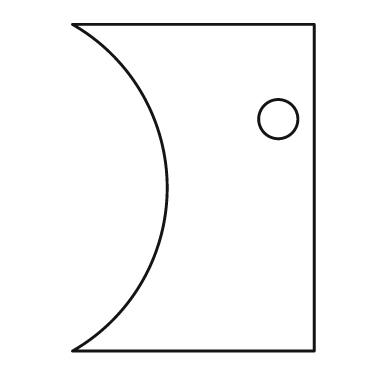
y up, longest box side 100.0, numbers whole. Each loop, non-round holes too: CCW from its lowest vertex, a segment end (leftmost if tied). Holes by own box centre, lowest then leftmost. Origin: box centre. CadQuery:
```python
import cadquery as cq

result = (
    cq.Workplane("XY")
    .moveTo(-37.0, -50.0)
    .lineTo(37.0, -50.0)
    .lineTo(37.0, 50.0)
    .lineTo(-37.0, 50.0)
    .threePointArc((-8.0, 0.0), (-37.0, -50.0))
    .close()
    .moveTo(26.0, 21.0)
    .circle(6.0)
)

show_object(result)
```